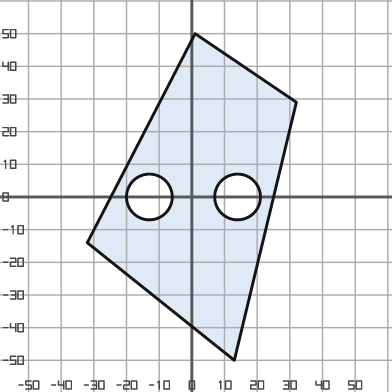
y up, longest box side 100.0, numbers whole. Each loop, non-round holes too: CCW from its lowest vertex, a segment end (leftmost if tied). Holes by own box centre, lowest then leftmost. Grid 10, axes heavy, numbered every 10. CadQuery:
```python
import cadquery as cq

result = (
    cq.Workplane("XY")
    .moveTo(13.0, -50.0)
    .lineTo(32.0, 29.0)
    .lineTo(1.0, 50.0)
    .lineTo(-32.0, -14.0)
    .close()
    .moveTo(-13.0, 0.0)
    .circle(7.0)
    .moveTo(14.0, 0.0)
    .circle(7.0)
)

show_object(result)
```